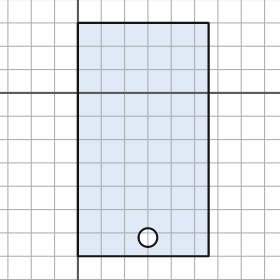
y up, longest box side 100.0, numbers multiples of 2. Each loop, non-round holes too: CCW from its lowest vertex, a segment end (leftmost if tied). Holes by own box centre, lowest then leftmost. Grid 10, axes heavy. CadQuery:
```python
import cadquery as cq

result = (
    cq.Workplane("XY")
    .moveTo(0.0, -70.0)
    .lineTo(56.0, -70.0)
    .lineTo(56.0, 30.0)
    .lineTo(0.0, 30.0)
    .close()
    .moveTo(30.0, -62.0)
    .circle(4.0)
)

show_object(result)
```